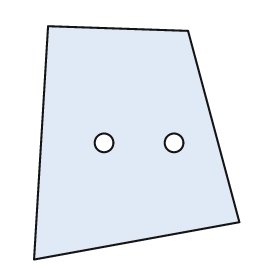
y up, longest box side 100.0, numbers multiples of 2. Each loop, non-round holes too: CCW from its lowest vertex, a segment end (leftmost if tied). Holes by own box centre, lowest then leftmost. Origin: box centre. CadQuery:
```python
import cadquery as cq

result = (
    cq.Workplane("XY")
    .moveTo(-44.0, -50.0)
    .lineTo(44.0, -34.0)
    .lineTo(22.0, 48.0)
    .lineTo(-38.0, 50.0)
    .close()
    .moveTo(-14.0, 0.0)
    .circle(4.0)
    .moveTo(16.0, 0.0)
    .circle(4.0)
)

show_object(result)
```